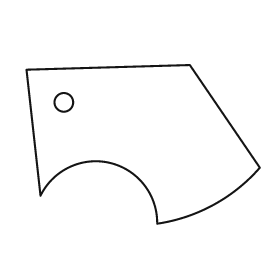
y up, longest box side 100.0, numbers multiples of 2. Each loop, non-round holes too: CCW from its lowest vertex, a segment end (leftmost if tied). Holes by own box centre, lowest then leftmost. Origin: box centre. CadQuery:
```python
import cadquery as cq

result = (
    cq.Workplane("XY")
    .moveTo(6.0, -34.0)
    .threePointArc((30.0, -26.0), (50.0, -10.0))
    .lineTo(20.0, 34.0)
    .lineTo(-50.0, 32.0)
    .lineTo(-44.0, -22.0)
    .threePointArc((-14.0, -8.0), (6.0, -34.0))
    .close()
    .moveTo(-34.0, 18.0)
    .circle(4.0)
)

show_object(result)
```